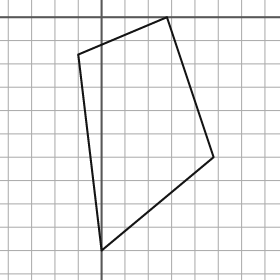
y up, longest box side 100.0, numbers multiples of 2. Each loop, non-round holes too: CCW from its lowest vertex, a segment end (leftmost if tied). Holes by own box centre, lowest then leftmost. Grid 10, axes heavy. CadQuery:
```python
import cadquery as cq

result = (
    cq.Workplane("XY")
    .moveTo(0.0, -100.0)
    .lineTo(48.0, -60.0)
    .lineTo(28.0, 0.0)
    .lineTo(-10.0, -16.0)
    .close()
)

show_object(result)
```